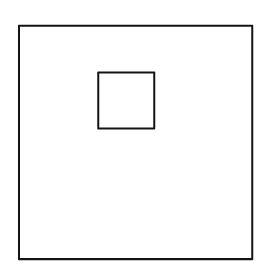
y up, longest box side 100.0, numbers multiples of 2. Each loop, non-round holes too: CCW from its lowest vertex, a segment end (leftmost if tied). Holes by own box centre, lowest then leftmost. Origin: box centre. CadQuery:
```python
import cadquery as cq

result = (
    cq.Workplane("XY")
    .moveTo(-50.0, -50.0)
    .lineTo(50.0, -50.0)
    .lineTo(50.0, 50.0)
    .lineTo(-50.0, 50.0)
    .close()
    .moveTo(-16.0, 6.0)
    .lineTo(8.0, 6.0)
    .lineTo(8.0, 30.0)
    .lineTo(-16.0, 30.0)
    .close()
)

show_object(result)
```